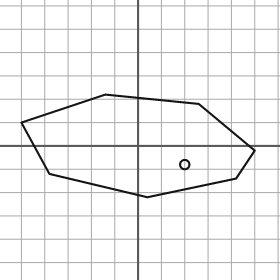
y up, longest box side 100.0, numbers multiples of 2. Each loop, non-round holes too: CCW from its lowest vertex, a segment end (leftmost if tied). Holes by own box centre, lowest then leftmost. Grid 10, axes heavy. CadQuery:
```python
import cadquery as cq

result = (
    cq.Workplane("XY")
    .moveTo(4.0, -22.0)
    .lineTo(42.0, -14.0)
    .lineTo(50.0, -2.0)
    .lineTo(26.0, 18.0)
    .lineTo(-14.0, 22.0)
    .lineTo(-50.0, 10.0)
    .lineTo(-38.0, -12.0)
    .close()
    .moveTo(20.0, -8.0)
    .circle(2.0)
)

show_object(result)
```